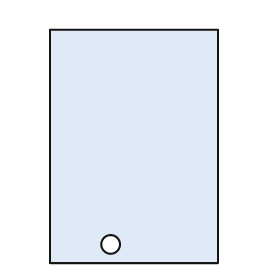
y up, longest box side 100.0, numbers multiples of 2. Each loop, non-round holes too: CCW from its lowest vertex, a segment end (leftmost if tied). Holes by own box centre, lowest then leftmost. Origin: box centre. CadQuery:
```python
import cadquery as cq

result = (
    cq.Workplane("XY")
    .moveTo(-36.0, -50.0)
    .lineTo(36.0, -50.0)
    .lineTo(36.0, 50.0)
    .lineTo(-36.0, 50.0)
    .close()
    .moveTo(-10.0, -42.0)
    .circle(4.0)
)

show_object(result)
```